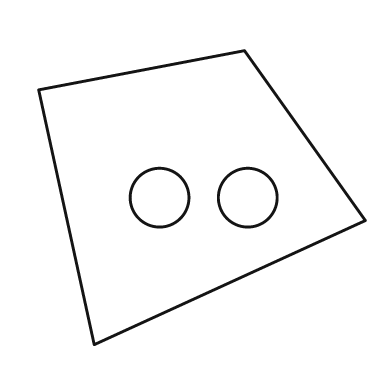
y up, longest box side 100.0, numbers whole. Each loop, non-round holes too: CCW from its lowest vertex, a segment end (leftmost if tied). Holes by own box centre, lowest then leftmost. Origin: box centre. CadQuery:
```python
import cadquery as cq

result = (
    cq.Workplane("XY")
    .moveTo(-33.0, -45.0)
    .lineTo(50.0, -7.0)
    .lineTo(13.0, 45.0)
    .lineTo(-50.0, 33.0)
    .close()
    .moveTo(-13.0, 0.0)
    .circle(9.0)
    .moveTo(14.0, 0.0)
    .circle(9.0)
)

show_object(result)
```